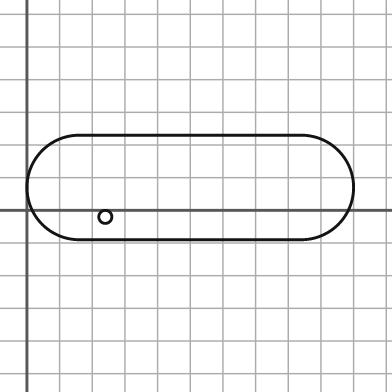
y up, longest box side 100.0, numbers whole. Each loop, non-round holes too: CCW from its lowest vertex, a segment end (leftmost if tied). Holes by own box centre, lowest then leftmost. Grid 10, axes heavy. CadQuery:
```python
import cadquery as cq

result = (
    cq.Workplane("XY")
    .moveTo(16.0, -9.0)
    .lineTo(84.0, -9.0)
    .threePointArc((100.0, 7.0), (84.0, 23.0))
    .lineTo(16.0, 23.0)
    .threePointArc((0.0, 7.0), (16.0, -9.0))
    .close()
    .moveTo(24.0, -2.0)
    .circle(2.0)
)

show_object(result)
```